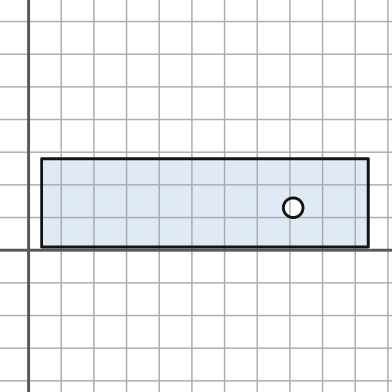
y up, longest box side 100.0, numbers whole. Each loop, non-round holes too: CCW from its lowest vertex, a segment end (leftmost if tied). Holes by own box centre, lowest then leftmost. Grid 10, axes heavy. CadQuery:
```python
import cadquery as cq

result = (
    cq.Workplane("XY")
    .moveTo(4.0, 1.0)
    .lineTo(104.0, 1.0)
    .lineTo(104.0, 28.0)
    .lineTo(4.0, 28.0)
    .close()
    .moveTo(81.0, 13.0)
    .circle(3.0)
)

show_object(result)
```